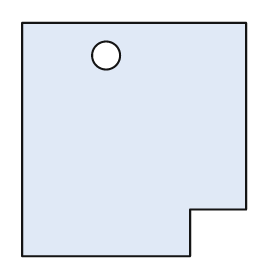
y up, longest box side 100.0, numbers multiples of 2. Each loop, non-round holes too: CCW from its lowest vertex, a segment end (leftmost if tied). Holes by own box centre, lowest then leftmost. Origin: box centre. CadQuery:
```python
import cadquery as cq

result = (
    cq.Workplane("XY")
    .moveTo(-48.0, -50.0)
    .lineTo(24.0, -50.0)
    .lineTo(24.0, -30.0)
    .lineTo(48.0, -30.0)
    .lineTo(48.0, 50.0)
    .lineTo(-48.0, 50.0)
    .close()
    .moveTo(-12.0, 36.0)
    .circle(6.0)
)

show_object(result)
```